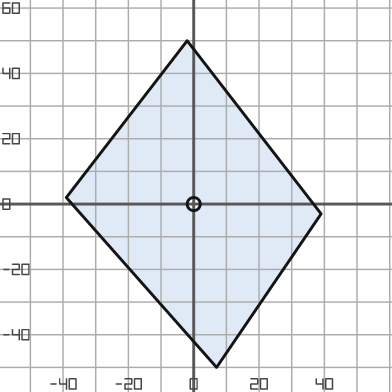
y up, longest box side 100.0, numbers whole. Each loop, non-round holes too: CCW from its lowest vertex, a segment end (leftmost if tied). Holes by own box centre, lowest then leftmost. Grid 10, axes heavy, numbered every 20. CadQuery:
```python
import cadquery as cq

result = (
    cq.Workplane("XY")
    .moveTo(7.0, -50.0)
    .lineTo(39.0, -3.0)
    .lineTo(-2.0, 50.0)
    .lineTo(-39.0, 2.0)
    .close()
    .moveTo(0.0, 0.0)
    .circle(2.0)
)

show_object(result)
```